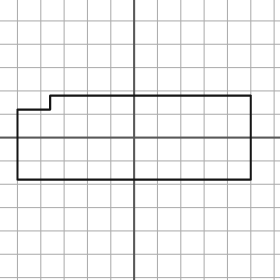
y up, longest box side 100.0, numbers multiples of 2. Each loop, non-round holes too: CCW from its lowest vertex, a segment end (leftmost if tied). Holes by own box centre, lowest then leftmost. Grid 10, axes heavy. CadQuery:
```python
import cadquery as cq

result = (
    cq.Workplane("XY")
    .moveTo(-50.0, -18.0)
    .lineTo(50.0, -18.0)
    .lineTo(50.0, 18.0)
    .lineTo(-36.0, 18.0)
    .lineTo(-36.0, 12.0)
    .lineTo(-50.0, 12.0)
    .close()
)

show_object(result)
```